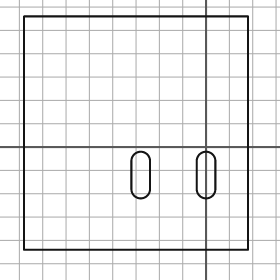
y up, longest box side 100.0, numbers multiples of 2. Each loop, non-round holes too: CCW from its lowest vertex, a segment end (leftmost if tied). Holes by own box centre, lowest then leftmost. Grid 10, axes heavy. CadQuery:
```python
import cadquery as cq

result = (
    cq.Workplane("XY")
    .moveTo(-78.0, -44.0)
    .lineTo(18.0, -44.0)
    .lineTo(18.0, 56.0)
    .lineTo(-78.0, 56.0)
    .close()
    .moveTo(-32.0, -18.0)
    .threePointArc((-28.0, -22.0), (-24.0, -18.0))
    .lineTo(-24.0, -6.0)
    .threePointArc((-28.0, -2.0), (-32.0, -6.0))
    .close()
    .moveTo(-4.0, -18.0)
    .threePointArc((0.0, -22.0), (4.0, -18.0))
    .lineTo(4.0, -6.0)
    .threePointArc((0.0, -2.0), (-4.0, -6.0))
    .close()
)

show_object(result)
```